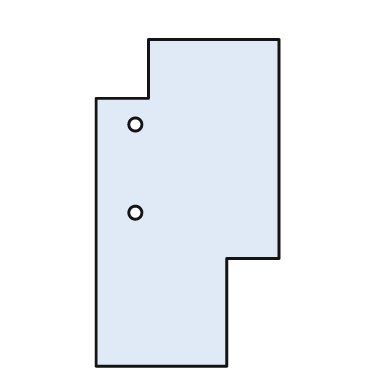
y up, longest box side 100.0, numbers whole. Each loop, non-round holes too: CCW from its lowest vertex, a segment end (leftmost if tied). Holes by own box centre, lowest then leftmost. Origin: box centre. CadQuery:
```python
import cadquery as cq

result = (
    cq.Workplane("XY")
    .moveTo(-28.0, -50.0)
    .lineTo(12.0, -50.0)
    .lineTo(12.0, -17.0)
    .lineTo(28.0, -17.0)
    .lineTo(28.0, 50.0)
    .lineTo(-12.0, 50.0)
    .lineTo(-12.0, 32.0)
    .lineTo(-28.0, 32.0)
    .close()
    .moveTo(-16.0, -3.0)
    .circle(2.0)
    .moveTo(-16.0, 24.0)
    .circle(2.0)
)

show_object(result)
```